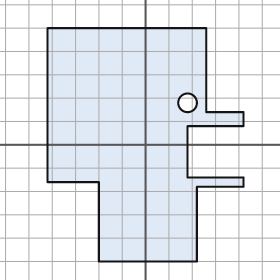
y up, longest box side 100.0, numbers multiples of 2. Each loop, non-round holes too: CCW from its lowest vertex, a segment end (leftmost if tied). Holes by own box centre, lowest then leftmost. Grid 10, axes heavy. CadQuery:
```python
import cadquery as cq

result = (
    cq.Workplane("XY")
    .moveTo(-20.0, -50.0)
    .lineTo(22.0, -50.0)
    .lineTo(22.0, -18.0)
    .lineTo(42.0, -18.0)
    .lineTo(42.0, -14.0)
    .lineTo(18.0, -14.0)
    .lineTo(18.0, 8.0)
    .lineTo(42.0, 8.0)
    .lineTo(42.0, 14.0)
    .lineTo(26.0, 14.0)
    .lineTo(26.0, 50.0)
    .lineTo(-42.0, 50.0)
    .lineTo(-42.0, -16.0)
    .lineTo(-20.0, -16.0)
    .close()
    .moveTo(18.0, 18.0)
    .circle(4.0)
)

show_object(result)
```